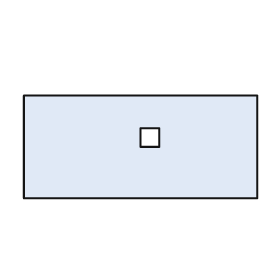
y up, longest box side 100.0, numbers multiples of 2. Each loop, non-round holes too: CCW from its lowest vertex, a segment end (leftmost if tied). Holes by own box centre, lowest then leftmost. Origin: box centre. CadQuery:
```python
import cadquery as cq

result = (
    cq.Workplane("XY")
    .moveTo(-50.0, -22.0)
    .lineTo(50.0, -22.0)
    .lineTo(50.0, 22.0)
    .lineTo(-50.0, 22.0)
    .close()
    .moveTo(0.0, 0.0)
    .lineTo(8.0, 0.0)
    .lineTo(8.0, 8.0)
    .lineTo(0.0, 8.0)
    .close()
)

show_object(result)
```